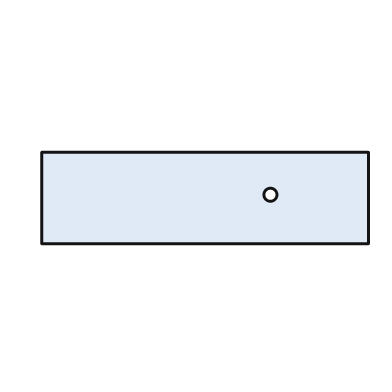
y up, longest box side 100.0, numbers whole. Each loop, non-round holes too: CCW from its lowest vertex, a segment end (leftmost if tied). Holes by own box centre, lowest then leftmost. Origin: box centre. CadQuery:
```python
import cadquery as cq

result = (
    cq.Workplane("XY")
    .moveTo(-50.0, -14.0)
    .lineTo(50.0, -14.0)
    .lineTo(50.0, 14.0)
    .lineTo(-50.0, 14.0)
    .close()
    .moveTo(20.0, 1.0)
    .circle(2.0)
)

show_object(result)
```